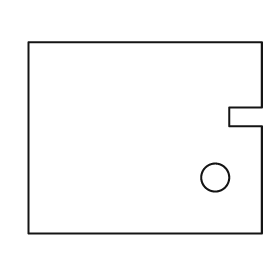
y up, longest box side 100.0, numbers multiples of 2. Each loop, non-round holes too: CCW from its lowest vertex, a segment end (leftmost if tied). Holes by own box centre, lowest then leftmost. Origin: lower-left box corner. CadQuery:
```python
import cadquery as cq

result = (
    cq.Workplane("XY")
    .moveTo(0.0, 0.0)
    .lineTo(100.0, 0.0)
    .lineTo(100.0, 46.0)
    .lineTo(86.0, 46.0)
    .lineTo(86.0, 54.0)
    .lineTo(100.0, 54.0)
    .lineTo(100.0, 82.0)
    .lineTo(0.0, 82.0)
    .close()
    .moveTo(80.0, 24.0)
    .circle(6.0)
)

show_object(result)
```